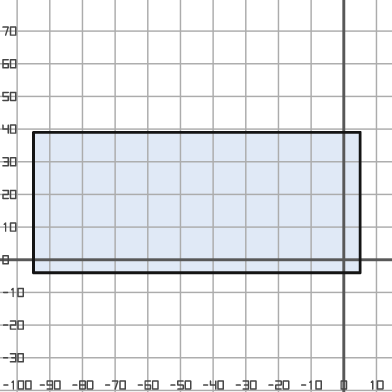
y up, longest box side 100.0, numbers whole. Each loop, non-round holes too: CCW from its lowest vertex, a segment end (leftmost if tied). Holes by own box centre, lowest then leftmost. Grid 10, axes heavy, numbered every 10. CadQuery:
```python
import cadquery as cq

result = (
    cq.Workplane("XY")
    .moveTo(-95.0, -4.0)
    .lineTo(5.0, -4.0)
    .lineTo(5.0, 39.0)
    .lineTo(-95.0, 39.0)
    .close()
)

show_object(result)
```